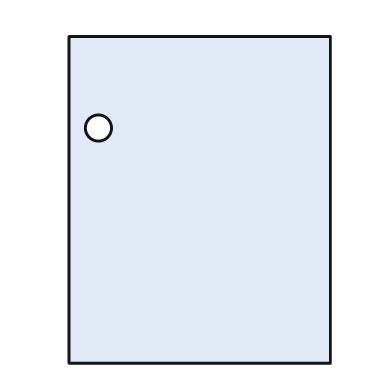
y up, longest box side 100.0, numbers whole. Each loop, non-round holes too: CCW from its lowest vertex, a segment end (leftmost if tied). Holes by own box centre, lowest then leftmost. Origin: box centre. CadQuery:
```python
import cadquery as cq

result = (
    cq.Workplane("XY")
    .moveTo(-40.0, -50.0)
    .lineTo(40.0, -50.0)
    .lineTo(40.0, 50.0)
    .lineTo(-40.0, 50.0)
    .close()
    .moveTo(-31.0, 22.0)
    .circle(4.0)
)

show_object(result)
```